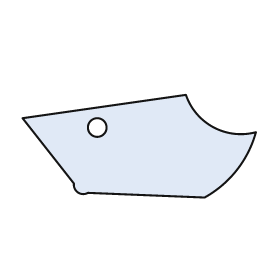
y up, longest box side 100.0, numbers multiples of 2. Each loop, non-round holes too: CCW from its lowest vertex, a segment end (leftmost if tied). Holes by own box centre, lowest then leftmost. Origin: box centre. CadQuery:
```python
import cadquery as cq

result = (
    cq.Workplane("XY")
    .moveTo(28.0, -22.0)
    .threePointArc((42.0, -10.0), (50.0, 6.0))
    .threePointArc((32.0, 8.0), (20.0, 22.0))
    .lineTo(-50.0, 12.0)
    .lineTo(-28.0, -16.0)
    .threePointArc((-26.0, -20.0), (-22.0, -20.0))
    .close()
    .moveTo(-18.0, 8.0)
    .circle(4.0)
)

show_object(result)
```